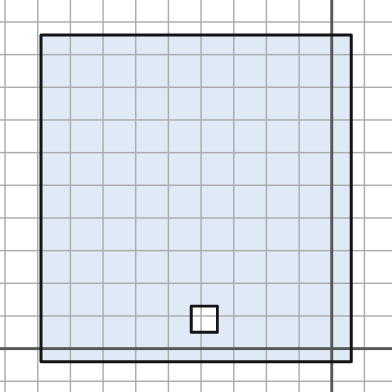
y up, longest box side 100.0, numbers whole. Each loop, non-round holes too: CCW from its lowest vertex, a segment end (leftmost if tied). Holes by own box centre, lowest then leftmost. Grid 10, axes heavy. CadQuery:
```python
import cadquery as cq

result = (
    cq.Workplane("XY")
    .moveTo(-89.0, -4.0)
    .lineTo(6.0, -4.0)
    .lineTo(6.0, 96.0)
    .lineTo(-89.0, 96.0)
    .close()
    .moveTo(-43.0, 5.0)
    .lineTo(-35.0, 5.0)
    .lineTo(-35.0, 13.0)
    .lineTo(-43.0, 13.0)
    .close()
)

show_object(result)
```